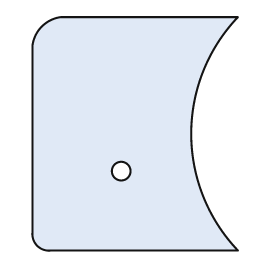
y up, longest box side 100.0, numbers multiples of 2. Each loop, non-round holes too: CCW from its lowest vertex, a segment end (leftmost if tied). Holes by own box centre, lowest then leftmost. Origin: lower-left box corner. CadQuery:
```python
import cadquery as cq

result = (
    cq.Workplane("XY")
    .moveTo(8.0, 0.0)
    .lineTo(88.0, 0.0)
    .threePointArc((68.0, 50.0), (88.0, 100.0))
    .lineTo(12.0, 100.0)
    .threePointArc((4.0, 96.0), (0.0, 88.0))
    .lineTo(0.0, 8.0)
    .threePointArc((2.0, 2.0), (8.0, 0.0))
    .close()
    .moveTo(38.0, 34.0)
    .circle(4.0)
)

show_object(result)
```